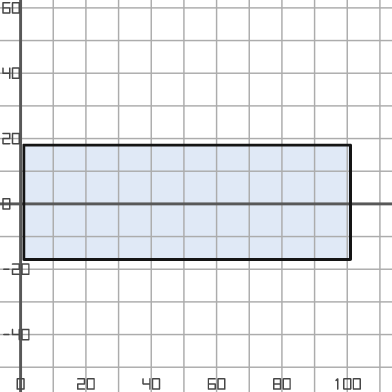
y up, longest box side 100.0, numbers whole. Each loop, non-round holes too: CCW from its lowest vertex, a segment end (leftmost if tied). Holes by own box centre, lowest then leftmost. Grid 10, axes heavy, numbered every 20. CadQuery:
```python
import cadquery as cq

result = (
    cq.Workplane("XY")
    .moveTo(1.0, -17.0)
    .lineTo(101.0, -17.0)
    .lineTo(101.0, 18.0)
    .lineTo(1.0, 18.0)
    .close()
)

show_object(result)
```